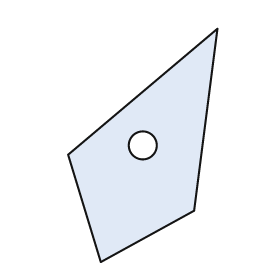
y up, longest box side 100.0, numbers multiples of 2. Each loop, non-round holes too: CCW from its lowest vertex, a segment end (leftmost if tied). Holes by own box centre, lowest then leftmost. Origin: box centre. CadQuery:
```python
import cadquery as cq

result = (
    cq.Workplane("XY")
    .moveTo(-18.0, -50.0)
    .lineTo(22.0, -28.0)
    .lineTo(32.0, 50.0)
    .lineTo(-32.0, -4.0)
    .close()
    .moveTo(0.0, 0.0)
    .circle(6.0)
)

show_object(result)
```